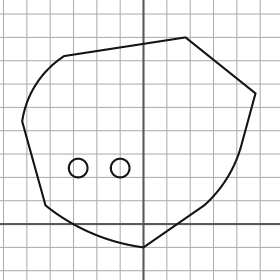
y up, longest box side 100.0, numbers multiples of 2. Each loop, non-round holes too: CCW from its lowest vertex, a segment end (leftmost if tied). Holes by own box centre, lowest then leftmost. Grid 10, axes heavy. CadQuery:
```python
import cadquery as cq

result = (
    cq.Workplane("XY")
    .moveTo(0.0, -10.0)
    .lineTo(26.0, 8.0)
    .threePointArc((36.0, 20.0), (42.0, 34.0))
    .lineTo(48.0, 56.0)
    .lineTo(18.0, 80.0)
    .lineTo(-34.0, 72.0)
    .threePointArc((-46.0, 60.0), (-52.0, 44.0))
    .lineTo(-42.0, 8.0)
    .threePointArc((-22.0, -4.0), (0.0, -10.0))
    .close()
    .moveTo(-28.0, 24.0)
    .circle(4.0)
    .moveTo(-10.0, 24.0)
    .circle(4.0)
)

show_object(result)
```